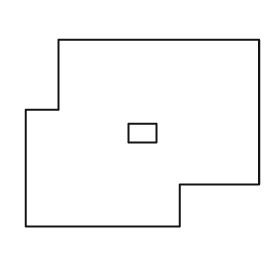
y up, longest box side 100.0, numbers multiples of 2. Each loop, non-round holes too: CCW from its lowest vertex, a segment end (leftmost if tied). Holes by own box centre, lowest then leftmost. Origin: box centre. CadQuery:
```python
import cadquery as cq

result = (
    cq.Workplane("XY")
    .moveTo(-50.0, -40.0)
    .lineTo(16.0, -40.0)
    .lineTo(16.0, -22.0)
    .lineTo(50.0, -22.0)
    .lineTo(50.0, 40.0)
    .lineTo(-36.0, 40.0)
    .lineTo(-36.0, 10.0)
    .lineTo(-50.0, 10.0)
    .close()
    .moveTo(-6.0, -4.0)
    .lineTo(6.0, -4.0)
    .lineTo(6.0, 4.0)
    .lineTo(-6.0, 4.0)
    .close()
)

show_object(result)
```